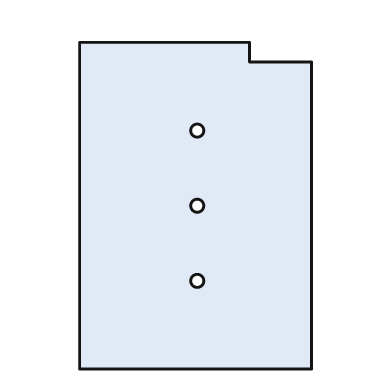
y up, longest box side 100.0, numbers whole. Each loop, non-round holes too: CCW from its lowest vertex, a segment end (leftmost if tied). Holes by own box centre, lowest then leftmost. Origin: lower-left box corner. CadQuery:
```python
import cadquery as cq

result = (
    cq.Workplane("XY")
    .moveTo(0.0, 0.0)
    .lineTo(71.0, 0.0)
    .lineTo(71.0, 94.0)
    .lineTo(52.0, 94.0)
    .lineTo(52.0, 100.0)
    .lineTo(0.0, 100.0)
    .close()
    .moveTo(36.0, 27.0)
    .circle(2.0)
    .moveTo(36.0, 50.0)
    .circle(2.0)
    .moveTo(36.0, 73.0)
    .circle(2.0)
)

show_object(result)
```